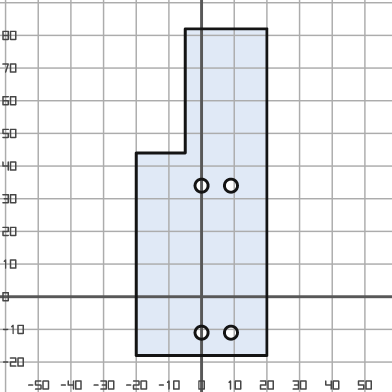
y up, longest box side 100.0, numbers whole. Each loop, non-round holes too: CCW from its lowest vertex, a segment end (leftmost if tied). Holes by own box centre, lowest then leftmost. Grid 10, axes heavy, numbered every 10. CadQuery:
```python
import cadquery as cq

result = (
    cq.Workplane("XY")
    .moveTo(-20.0, -18.0)
    .lineTo(20.0, -18.0)
    .lineTo(20.0, 82.0)
    .lineTo(-5.0, 82.0)
    .lineTo(-5.0, 44.0)
    .lineTo(-20.0, 44.0)
    .close()
    .moveTo(0.0, -11.0)
    .circle(2.0)
    .moveTo(9.0, -11.0)
    .circle(2.0)
    .moveTo(0.0, 34.0)
    .circle(2.0)
    .moveTo(9.0, 34.0)
    .circle(2.0)
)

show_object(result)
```